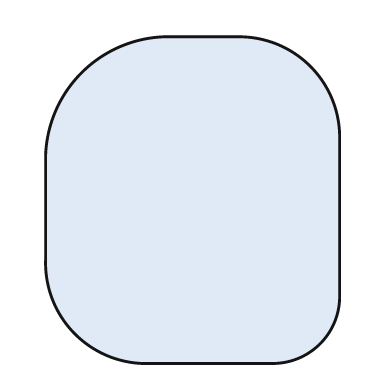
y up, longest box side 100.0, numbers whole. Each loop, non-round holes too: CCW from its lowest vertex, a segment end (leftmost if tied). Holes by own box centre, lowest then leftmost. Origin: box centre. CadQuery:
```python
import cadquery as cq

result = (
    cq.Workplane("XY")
    .moveTo(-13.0, -50.0)
    .lineTo(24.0, -50.0)
    .threePointArc((39.0, -44.0), (45.0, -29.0))
    .lineTo(45.0, 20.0)
    .threePointArc((36.0, 41.0), (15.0, 50.0))
    .lineTo(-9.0, 50.0)
    .threePointArc((-34.0, 39.0), (-45.0, 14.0))
    .lineTo(-45.0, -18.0)
    .threePointArc((-36.0, -41.0), (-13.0, -50.0))
    .close()
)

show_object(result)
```